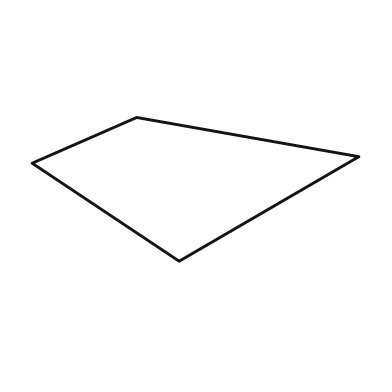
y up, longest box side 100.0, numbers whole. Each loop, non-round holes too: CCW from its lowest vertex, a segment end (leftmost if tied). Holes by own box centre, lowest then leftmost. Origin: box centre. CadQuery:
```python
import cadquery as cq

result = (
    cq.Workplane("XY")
    .moveTo(-5.0, -22.0)
    .lineTo(50.0, 10.0)
    .lineTo(-18.0, 22.0)
    .lineTo(-50.0, 8.0)
    .close()
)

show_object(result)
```